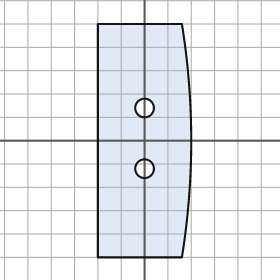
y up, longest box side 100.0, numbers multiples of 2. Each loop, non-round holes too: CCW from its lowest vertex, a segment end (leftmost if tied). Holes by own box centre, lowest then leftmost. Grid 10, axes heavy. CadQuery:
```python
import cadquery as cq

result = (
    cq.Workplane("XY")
    .moveTo(-20.0, -50.0)
    .lineTo(16.0, -50.0)
    .threePointArc((20.0, 0.0), (16.0, 50.0))
    .lineTo(-20.0, 50.0)
    .close()
    .moveTo(0.0, -12.0)
    .circle(4.0)
    .moveTo(0.0, 14.0)
    .circle(4.0)
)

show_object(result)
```